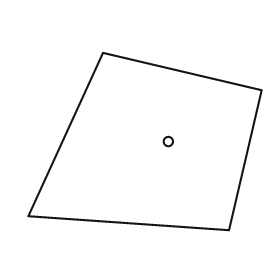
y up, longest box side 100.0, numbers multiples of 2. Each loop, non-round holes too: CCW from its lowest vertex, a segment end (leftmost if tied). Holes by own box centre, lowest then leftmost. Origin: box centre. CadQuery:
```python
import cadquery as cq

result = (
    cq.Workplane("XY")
    .moveTo(36.0, -38.0)
    .lineTo(50.0, 22.0)
    .lineTo(-18.0, 38.0)
    .lineTo(-50.0, -32.0)
    .close()
    .moveTo(10.0, 0.0)
    .circle(2.0)
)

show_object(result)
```